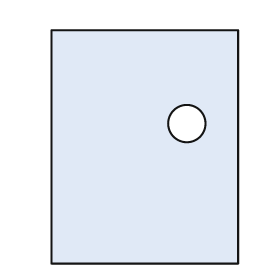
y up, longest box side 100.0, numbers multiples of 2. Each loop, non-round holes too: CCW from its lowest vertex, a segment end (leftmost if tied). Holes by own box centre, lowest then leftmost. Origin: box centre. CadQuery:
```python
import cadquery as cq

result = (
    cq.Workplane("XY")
    .moveTo(-40.0, -50.0)
    .lineTo(40.0, -50.0)
    .lineTo(40.0, 50.0)
    .lineTo(-40.0, 50.0)
    .close()
    .moveTo(18.0, 10.0)
    .circle(8.0)
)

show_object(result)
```